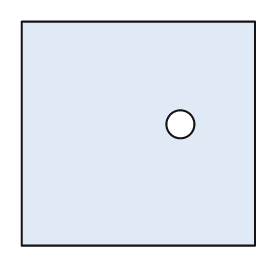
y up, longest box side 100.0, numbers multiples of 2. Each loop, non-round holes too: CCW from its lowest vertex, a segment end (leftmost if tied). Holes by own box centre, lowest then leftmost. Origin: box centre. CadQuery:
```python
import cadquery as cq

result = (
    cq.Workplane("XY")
    .moveTo(-50.0, -48.0)
    .lineTo(50.0, -48.0)
    .lineTo(50.0, 48.0)
    .lineTo(-50.0, 48.0)
    .close()
    .moveTo(18.0, 4.0)
    .circle(6.0)
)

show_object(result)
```